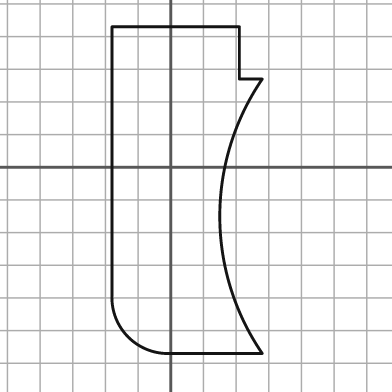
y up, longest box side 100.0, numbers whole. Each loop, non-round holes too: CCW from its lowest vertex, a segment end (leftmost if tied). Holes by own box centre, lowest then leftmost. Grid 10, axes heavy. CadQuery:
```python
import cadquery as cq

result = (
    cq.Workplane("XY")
    .moveTo(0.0, -57.0)
    .lineTo(28.0, -57.0)
    .threePointArc((15.0, -15.0), (28.0, 27.0))
    .lineTo(21.0, 27.0)
    .lineTo(21.0, 43.0)
    .lineTo(-18.0, 43.0)
    .lineTo(-18.0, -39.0)
    .threePointArc((-13.0, -52.0), (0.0, -57.0))
    .close()
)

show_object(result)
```